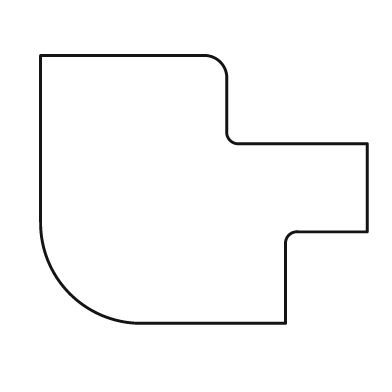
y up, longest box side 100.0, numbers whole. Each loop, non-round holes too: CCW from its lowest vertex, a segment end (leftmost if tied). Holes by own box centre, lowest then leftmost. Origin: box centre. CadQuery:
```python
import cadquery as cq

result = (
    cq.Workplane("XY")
    .moveTo(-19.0, -41.0)
    .lineTo(25.0, -41.0)
    .lineTo(25.0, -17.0)
    .threePointArc((26.0, -14.0), (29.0, -13.0))
    .lineTo(50.0, -13.0)
    .lineTo(50.0, 14.0)
    .lineTo(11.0, 14.0)
    .threePointArc((8.0, 15.0), (7.0, 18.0))
    .lineTo(7.0, 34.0)
    .threePointArc((5.0, 39.0), (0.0, 41.0))
    .lineTo(-50.0, 41.0)
    .lineTo(-50.0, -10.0)
    .threePointArc((-41.0, -32.0), (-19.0, -41.0))
    .close()
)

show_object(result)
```